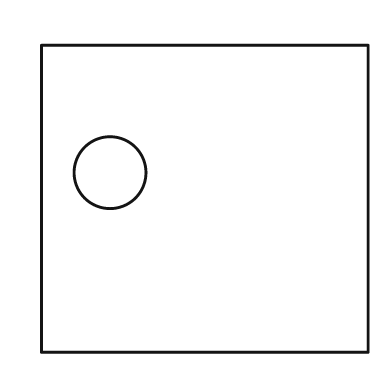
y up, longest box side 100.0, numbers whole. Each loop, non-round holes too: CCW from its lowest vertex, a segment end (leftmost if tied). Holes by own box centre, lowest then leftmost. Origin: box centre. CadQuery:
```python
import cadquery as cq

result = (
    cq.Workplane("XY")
    .moveTo(-50.0, -47.0)
    .lineTo(50.0, -47.0)
    .lineTo(50.0, 47.0)
    .lineTo(-50.0, 47.0)
    .close()
    .moveTo(-29.0, 8.0)
    .circle(11.0)
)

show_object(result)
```